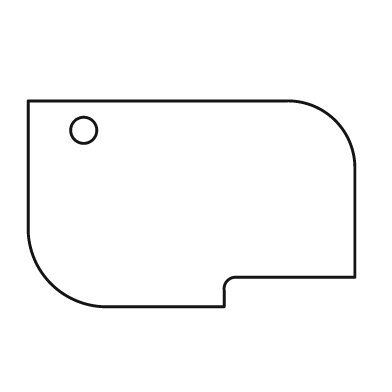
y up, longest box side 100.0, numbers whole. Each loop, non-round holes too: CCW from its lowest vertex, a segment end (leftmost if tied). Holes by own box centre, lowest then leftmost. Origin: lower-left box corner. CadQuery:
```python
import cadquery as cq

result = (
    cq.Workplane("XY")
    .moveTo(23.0, 0.0)
    .lineTo(60.0, 0.0)
    .lineTo(60.0, 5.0)
    .threePointArc((61.0, 8.0), (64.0, 9.0))
    .lineTo(100.0, 9.0)
    .lineTo(100.0, 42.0)
    .threePointArc((94.0, 57.0), (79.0, 63.0))
    .lineTo(0.0, 63.0)
    .lineTo(0.0, 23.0)
    .threePointArc((7.0, 7.0), (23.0, 0.0))
    .close()
    .moveTo(17.0, 54.0)
    .circle(4.0)
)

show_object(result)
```